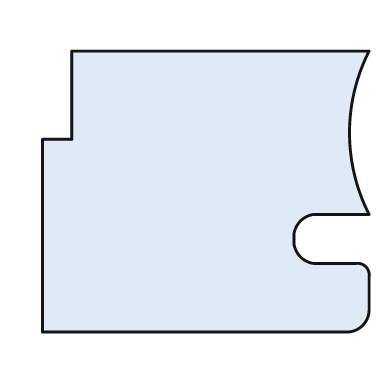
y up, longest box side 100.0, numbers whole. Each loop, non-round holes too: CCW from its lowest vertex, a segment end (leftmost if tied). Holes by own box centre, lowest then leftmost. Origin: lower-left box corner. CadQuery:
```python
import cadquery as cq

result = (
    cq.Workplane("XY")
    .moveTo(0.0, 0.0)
    .lineTo(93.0, 0.0)
    .threePointArc((98.0, 2.0), (100.0, 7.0))
    .lineTo(100.0, 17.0)
    .threePointArc((99.0, 20.0), (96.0, 21.0))
    .lineTo(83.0, 21.0)
    .threePointArc((79.0, 23.0), (77.0, 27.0))
    .lineTo(77.0, 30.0)
    .threePointArc((79.0, 34.0), (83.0, 36.0))
    .lineTo(100.0, 36.0)
    .threePointArc((94.0, 61.0), (100.0, 86.0))
    .lineTo(9.0, 86.0)
    .lineTo(9.0, 59.0)
    .lineTo(0.0, 59.0)
    .close()
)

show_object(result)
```